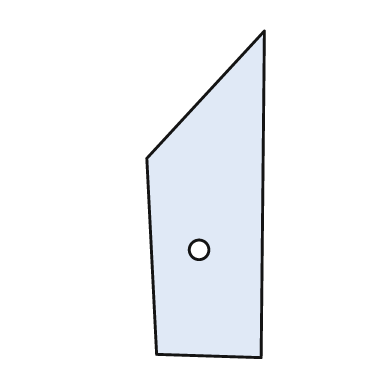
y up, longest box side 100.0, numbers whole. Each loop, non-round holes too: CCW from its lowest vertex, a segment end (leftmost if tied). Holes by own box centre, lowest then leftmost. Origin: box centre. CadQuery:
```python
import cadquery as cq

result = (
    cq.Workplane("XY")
    .moveTo(17.0, -50.0)
    .lineTo(18.0, 50.0)
    .lineTo(-18.0, 11.0)
    .lineTo(-15.0, -49.0)
    .close()
    .moveTo(-2.0, -17.0)
    .circle(3.0)
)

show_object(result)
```